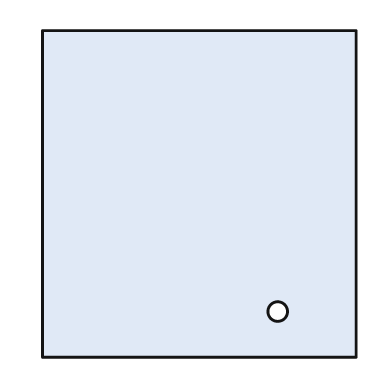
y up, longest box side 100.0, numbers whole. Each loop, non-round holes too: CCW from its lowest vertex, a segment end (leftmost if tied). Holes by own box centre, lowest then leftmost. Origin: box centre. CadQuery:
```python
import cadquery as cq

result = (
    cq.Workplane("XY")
    .moveTo(-48.0, -50.0)
    .lineTo(48.0, -50.0)
    .lineTo(48.0, 50.0)
    .lineTo(-48.0, 50.0)
    .close()
    .moveTo(24.0, -36.0)
    .circle(3.0)
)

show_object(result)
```